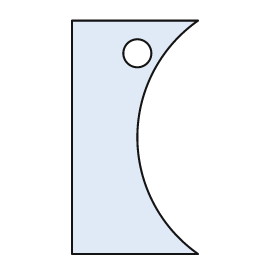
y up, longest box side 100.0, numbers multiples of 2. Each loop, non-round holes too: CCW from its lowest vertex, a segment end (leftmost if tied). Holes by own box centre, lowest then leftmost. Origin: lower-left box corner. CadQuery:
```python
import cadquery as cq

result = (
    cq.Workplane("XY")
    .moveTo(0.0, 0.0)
    .lineTo(54.0, 0.0)
    .threePointArc((28.0, 50.0), (54.0, 100.0))
    .lineTo(0.0, 100.0)
    .close()
    .moveTo(28.0, 86.0)
    .circle(6.0)
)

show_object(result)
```